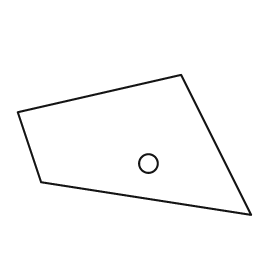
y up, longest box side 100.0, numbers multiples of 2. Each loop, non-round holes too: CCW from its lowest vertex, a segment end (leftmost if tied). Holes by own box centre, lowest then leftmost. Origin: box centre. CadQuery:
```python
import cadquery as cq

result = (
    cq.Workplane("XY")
    .moveTo(50.0, -30.0)
    .lineTo(20.0, 30.0)
    .lineTo(-50.0, 14.0)
    .lineTo(-40.0, -16.0)
    .close()
    .moveTo(6.0, -8.0)
    .circle(4.0)
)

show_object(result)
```